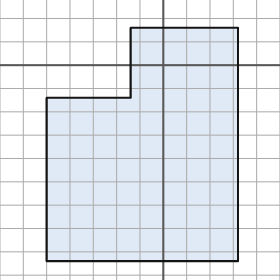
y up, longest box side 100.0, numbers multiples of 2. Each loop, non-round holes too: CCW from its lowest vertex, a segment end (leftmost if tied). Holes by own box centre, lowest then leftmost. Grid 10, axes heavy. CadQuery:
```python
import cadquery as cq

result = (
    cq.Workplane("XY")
    .moveTo(-50.0, -84.0)
    .lineTo(32.0, -84.0)
    .lineTo(32.0, 16.0)
    .lineTo(-14.0, 16.0)
    .lineTo(-14.0, -14.0)
    .lineTo(-50.0, -14.0)
    .close()
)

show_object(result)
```